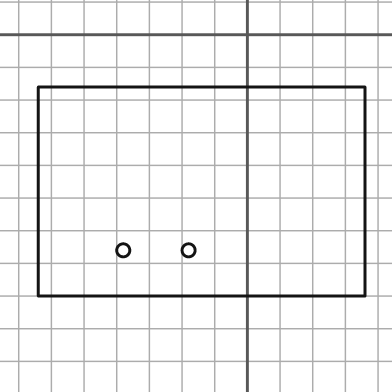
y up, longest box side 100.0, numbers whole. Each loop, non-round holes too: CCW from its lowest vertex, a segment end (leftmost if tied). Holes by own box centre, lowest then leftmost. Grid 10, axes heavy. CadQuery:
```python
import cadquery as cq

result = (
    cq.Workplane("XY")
    .moveTo(-64.0, -80.0)
    .lineTo(36.0, -80.0)
    .lineTo(36.0, -16.0)
    .lineTo(-64.0, -16.0)
    .close()
    .moveTo(-38.0, -66.0)
    .circle(2.0)
    .moveTo(-18.0, -66.0)
    .circle(2.0)
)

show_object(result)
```